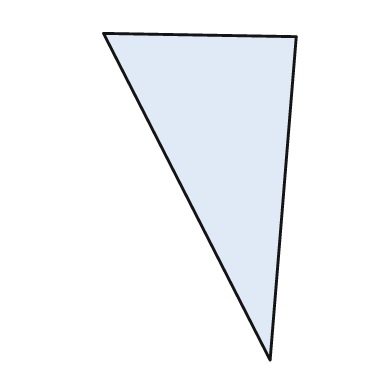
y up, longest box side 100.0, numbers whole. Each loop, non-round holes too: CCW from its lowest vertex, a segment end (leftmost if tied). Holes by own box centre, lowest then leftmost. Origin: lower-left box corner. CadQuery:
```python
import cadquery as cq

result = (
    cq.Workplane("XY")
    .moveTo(51.0, 0.0)
    .lineTo(59.0, 99.0)
    .lineTo(0.0, 100.0)
    .close()
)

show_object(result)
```